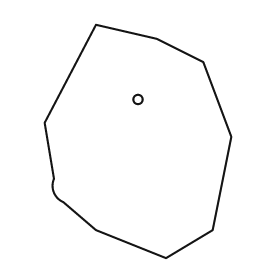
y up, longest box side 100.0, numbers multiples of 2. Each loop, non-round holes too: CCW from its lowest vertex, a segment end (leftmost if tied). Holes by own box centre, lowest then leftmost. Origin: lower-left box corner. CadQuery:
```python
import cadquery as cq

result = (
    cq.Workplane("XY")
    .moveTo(52.0, 0.0)
    .lineTo(72.0, 12.0)
    .lineTo(80.0, 52.0)
    .lineTo(68.0, 84.0)
    .lineTo(48.0, 94.0)
    .lineTo(22.0, 100.0)
    .lineTo(0.0, 58.0)
    .lineTo(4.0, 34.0)
    .threePointArc((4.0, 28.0), (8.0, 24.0))
    .lineTo(22.0, 12.0)
    .close()
    .moveTo(40.0, 68.0)
    .circle(2.0)
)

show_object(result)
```